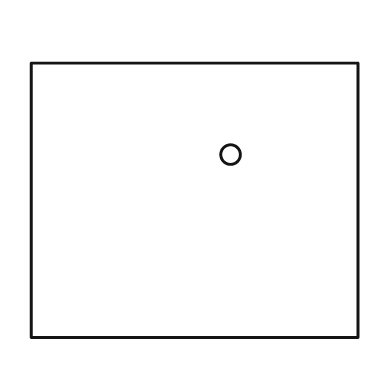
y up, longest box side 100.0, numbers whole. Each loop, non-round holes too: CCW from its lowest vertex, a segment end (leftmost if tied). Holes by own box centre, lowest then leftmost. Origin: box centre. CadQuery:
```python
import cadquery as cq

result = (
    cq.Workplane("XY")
    .moveTo(-50.0, -42.0)
    .lineTo(50.0, -42.0)
    .lineTo(50.0, 42.0)
    .lineTo(-50.0, 42.0)
    .close()
    .moveTo(11.0, 14.0)
    .circle(3.0)
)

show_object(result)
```